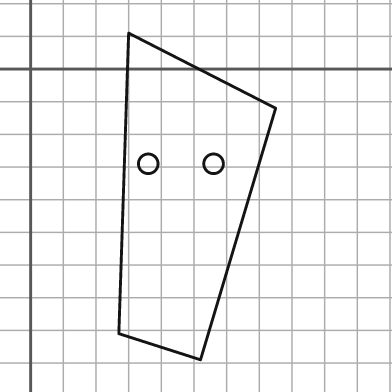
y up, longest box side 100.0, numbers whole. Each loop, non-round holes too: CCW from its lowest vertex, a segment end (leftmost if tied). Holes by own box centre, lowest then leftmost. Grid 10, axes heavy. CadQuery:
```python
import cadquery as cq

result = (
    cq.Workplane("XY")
    .moveTo(52.0, -89.0)
    .lineTo(75.0, -12.0)
    .lineTo(30.0, 11.0)
    .lineTo(27.0, -81.0)
    .close()
    .moveTo(36.0, -29.0)
    .circle(3.0)
    .moveTo(56.0, -29.0)
    .circle(3.0)
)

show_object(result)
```